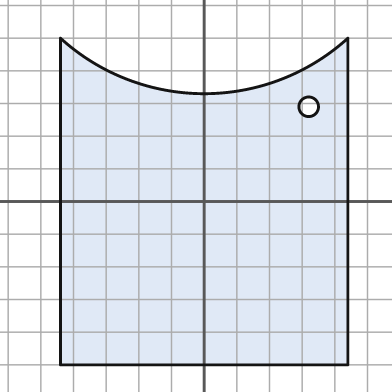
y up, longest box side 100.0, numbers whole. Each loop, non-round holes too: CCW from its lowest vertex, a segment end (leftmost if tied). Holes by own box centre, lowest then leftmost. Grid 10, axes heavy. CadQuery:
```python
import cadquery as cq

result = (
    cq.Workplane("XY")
    .moveTo(-44.0, -50.0)
    .lineTo(44.0, -50.0)
    .lineTo(44.0, 50.0)
    .threePointArc((0.0, 33.0), (-44.0, 50.0))
    .close()
    .moveTo(32.0, 29.0)
    .circle(3.0)
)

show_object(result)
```